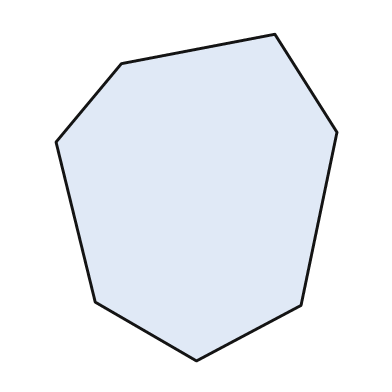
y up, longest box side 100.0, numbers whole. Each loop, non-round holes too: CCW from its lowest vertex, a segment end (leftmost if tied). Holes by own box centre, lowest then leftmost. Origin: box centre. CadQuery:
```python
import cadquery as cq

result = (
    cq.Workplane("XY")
    .moveTo(0.0, -50.0)
    .lineTo(32.0, -33.0)
    .lineTo(43.0, 20.0)
    .lineTo(24.0, 50.0)
    .lineTo(-23.0, 41.0)
    .lineTo(-43.0, 17.0)
    .lineTo(-31.0, -32.0)
    .close()
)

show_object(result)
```